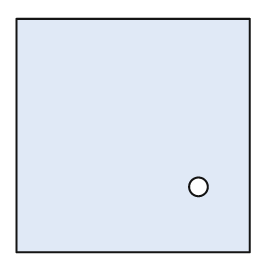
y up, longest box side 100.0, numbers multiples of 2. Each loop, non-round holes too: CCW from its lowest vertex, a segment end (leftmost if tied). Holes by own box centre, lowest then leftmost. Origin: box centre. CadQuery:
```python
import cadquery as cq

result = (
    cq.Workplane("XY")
    .moveTo(-50.0, -50.0)
    .lineTo(50.0, -50.0)
    .lineTo(50.0, 50.0)
    .lineTo(-50.0, 50.0)
    .close()
    .moveTo(28.0, -22.0)
    .circle(4.0)
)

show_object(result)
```